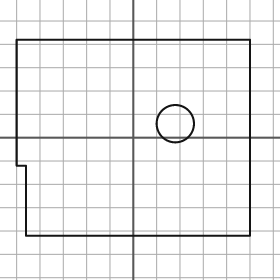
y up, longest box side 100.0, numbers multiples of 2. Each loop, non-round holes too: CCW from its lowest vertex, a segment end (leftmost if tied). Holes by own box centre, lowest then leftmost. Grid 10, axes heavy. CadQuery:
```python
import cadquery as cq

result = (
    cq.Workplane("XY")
    .moveTo(-46.0, -42.0)
    .lineTo(50.0, -42.0)
    .lineTo(50.0, 42.0)
    .lineTo(-50.0, 42.0)
    .lineTo(-50.0, -12.0)
    .lineTo(-46.0, -12.0)
    .close()
    .moveTo(18.0, 6.0)
    .circle(8.0)
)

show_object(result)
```